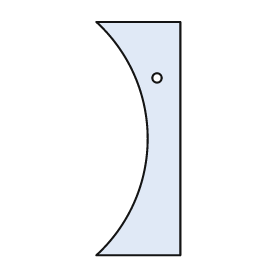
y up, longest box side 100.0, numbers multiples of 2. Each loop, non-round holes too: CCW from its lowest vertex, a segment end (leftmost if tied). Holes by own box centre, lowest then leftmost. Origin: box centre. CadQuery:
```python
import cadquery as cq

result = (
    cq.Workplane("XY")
    .moveTo(-18.0, -50.0)
    .lineTo(18.0, -50.0)
    .lineTo(18.0, 50.0)
    .lineTo(-18.0, 50.0)
    .threePointArc((4.0, 0.0), (-18.0, -50.0))
    .close()
    .moveTo(8.0, 26.0)
    .circle(2.0)
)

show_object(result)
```